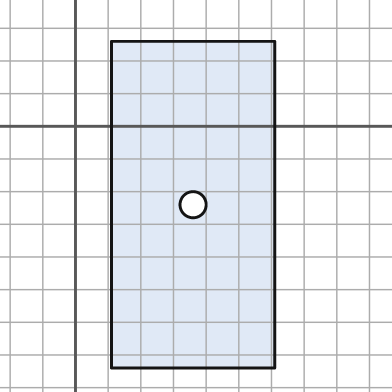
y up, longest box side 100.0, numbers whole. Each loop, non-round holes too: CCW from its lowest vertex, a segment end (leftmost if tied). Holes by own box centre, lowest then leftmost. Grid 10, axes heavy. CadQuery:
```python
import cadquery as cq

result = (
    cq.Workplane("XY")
    .moveTo(11.0, -74.0)
    .lineTo(61.0, -74.0)
    .lineTo(61.0, 26.0)
    .lineTo(11.0, 26.0)
    .close()
    .moveTo(36.0, -24.0)
    .circle(4.0)
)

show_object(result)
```